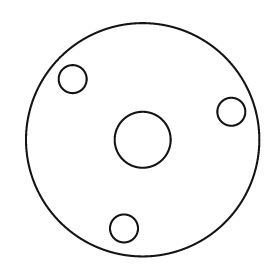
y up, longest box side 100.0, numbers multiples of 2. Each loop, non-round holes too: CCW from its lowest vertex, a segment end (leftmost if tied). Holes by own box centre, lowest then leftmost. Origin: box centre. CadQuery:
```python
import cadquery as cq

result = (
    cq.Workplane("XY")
    .moveTo(0.0, 0.0)
    .circle(50.0)
    .moveTo(-8.0, -38.0)
    .circle(6.0)
    .moveTo(0.0, 0.0)
    .circle(12.0)
    .moveTo(38.0, 12.0)
    .circle(6.0)
    .moveTo(-30.0, 26.0)
    .circle(6.0)
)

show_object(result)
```